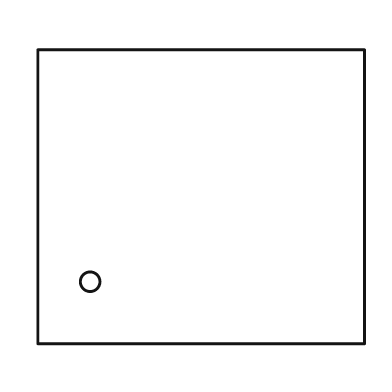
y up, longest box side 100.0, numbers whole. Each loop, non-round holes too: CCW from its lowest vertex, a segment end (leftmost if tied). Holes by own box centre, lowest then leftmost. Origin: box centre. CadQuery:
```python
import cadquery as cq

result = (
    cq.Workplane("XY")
    .moveTo(-50.0, -45.0)
    .lineTo(50.0, -45.0)
    .lineTo(50.0, 45.0)
    .lineTo(-50.0, 45.0)
    .close()
    .moveTo(-34.0, -26.0)
    .circle(3.0)
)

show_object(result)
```